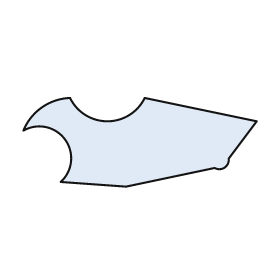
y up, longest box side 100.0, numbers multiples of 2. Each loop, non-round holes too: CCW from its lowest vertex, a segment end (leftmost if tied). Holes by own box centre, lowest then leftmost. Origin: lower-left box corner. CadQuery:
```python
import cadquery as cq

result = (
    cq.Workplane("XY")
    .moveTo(44.0, 0.0)
    .lineTo(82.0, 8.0)
    .threePointArc((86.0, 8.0), (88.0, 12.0))
    .lineTo(100.0, 28.0)
    .lineTo(52.0, 38.0)
    .threePointArc((36.0, 28.0), (20.0, 38.0))
    .threePointArc((8.0, 34.0), (0.0, 24.0))
    .threePointArc((18.0, 20.0), (16.0, 2.0))
    .close()
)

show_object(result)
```